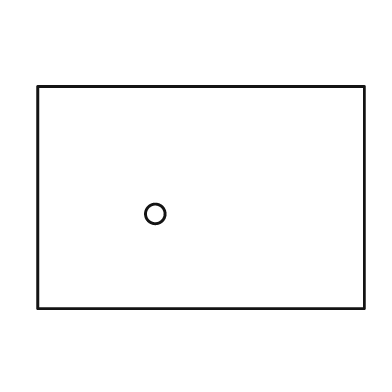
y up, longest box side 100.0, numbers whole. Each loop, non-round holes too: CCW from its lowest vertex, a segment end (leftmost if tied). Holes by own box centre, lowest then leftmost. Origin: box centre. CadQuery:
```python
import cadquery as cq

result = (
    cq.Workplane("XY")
    .moveTo(-50.0, -34.0)
    .lineTo(50.0, -34.0)
    .lineTo(50.0, 34.0)
    .lineTo(-50.0, 34.0)
    .close()
    .moveTo(-14.0, -5.0)
    .circle(3.0)
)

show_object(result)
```